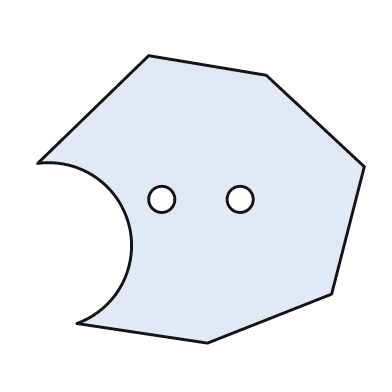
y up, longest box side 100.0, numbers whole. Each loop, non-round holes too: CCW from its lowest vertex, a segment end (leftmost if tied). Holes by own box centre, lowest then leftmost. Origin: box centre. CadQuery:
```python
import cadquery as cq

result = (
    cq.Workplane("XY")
    .moveTo(2.0, -44.0)
    .lineTo(40.0, -29.0)
    .lineTo(50.0, 10.0)
    .lineTo(20.0, 38.0)
    .lineTo(-16.0, 44.0)
    .lineTo(-50.0, 11.0)
    .threePointArc((-22.0, -8.0), (-38.0, -38.0))
    .close()
    .moveTo(-12.0, 0.0)
    .circle(4.0)
    .moveTo(12.0, 0.0)
    .circle(4.0)
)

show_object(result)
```